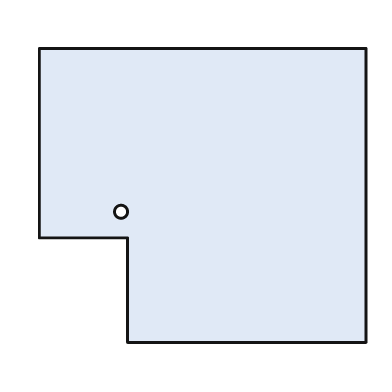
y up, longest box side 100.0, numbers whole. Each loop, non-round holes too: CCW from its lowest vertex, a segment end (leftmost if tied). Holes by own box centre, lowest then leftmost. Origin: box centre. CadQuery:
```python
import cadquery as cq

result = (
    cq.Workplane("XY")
    .moveTo(-23.0, -45.0)
    .lineTo(50.0, -45.0)
    .lineTo(50.0, 45.0)
    .lineTo(-50.0, 45.0)
    .lineTo(-50.0, -13.0)
    .lineTo(-23.0, -13.0)
    .close()
    .moveTo(-25.0, -5.0)
    .circle(2.0)
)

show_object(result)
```